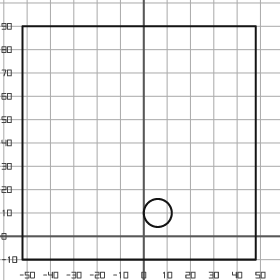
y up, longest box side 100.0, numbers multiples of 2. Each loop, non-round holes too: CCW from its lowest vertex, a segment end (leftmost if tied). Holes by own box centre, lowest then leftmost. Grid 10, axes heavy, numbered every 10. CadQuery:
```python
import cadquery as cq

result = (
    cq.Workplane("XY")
    .moveTo(-52.0, -10.0)
    .lineTo(48.0, -10.0)
    .lineTo(48.0, 90.0)
    .lineTo(-52.0, 90.0)
    .close()
    .moveTo(6.0, 10.0)
    .circle(6.0)
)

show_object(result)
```